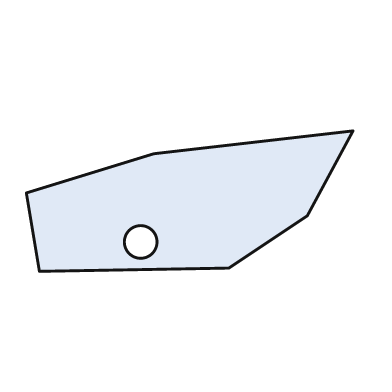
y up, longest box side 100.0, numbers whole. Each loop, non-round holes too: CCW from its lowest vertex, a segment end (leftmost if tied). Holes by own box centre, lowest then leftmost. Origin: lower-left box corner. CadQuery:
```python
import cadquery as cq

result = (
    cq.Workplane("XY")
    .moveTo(4.0, 0.0)
    .lineTo(62.0, 1.0)
    .lineTo(86.0, 17.0)
    .lineTo(100.0, 43.0)
    .lineTo(39.0, 36.0)
    .lineTo(0.0, 24.0)
    .close()
    .moveTo(35.0, 9.0)
    .circle(5.0)
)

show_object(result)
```